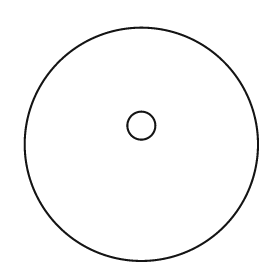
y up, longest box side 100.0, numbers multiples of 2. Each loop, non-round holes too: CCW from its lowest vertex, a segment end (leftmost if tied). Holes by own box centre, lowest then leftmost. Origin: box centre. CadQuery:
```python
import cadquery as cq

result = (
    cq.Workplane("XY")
    .moveTo(0.0, 0.0)
    .circle(50.0)
    .moveTo(0.0, 8.0)
    .circle(6.0)
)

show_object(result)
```